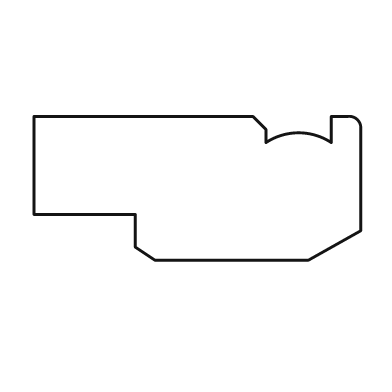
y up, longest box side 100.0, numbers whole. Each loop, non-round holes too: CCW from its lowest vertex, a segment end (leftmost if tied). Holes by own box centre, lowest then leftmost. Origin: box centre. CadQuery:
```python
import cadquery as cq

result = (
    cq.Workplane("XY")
    .moveTo(-13.0, -22.0)
    .lineTo(34.0, -22.0)
    .lineTo(50.0, -13.0)
    .lineTo(50.0, 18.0)
    .threePointArc((49.0, 21.0), (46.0, 22.0))
    .lineTo(41.0, 22.0)
    .lineTo(41.0, 14.0)
    .threePointArc((31.0, 17.0), (21.0, 14.0))
    .lineTo(21.0, 18.0)
    .lineTo(17.0, 22.0)
    .lineTo(-50.0, 22.0)
    .lineTo(-50.0, -8.0)
    .lineTo(-19.0, -8.0)
    .lineTo(-19.0, -18.0)
    .close()
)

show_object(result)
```